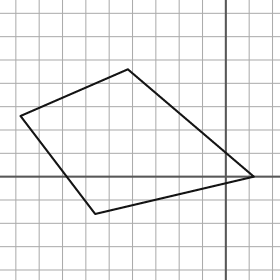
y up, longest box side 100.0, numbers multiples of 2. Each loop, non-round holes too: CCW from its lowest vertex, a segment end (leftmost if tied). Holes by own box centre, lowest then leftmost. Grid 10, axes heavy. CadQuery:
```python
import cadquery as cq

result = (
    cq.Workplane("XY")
    .moveTo(-56.0, -16.0)
    .lineTo(12.0, 0.0)
    .lineTo(-42.0, 46.0)
    .lineTo(-88.0, 26.0)
    .close()
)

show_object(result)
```